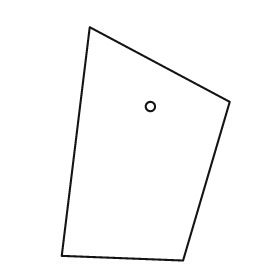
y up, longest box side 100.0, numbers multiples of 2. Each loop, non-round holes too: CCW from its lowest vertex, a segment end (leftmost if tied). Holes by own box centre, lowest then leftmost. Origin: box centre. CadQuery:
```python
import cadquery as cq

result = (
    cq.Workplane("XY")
    .moveTo(16.0, -50.0)
    .lineTo(36.0, 18.0)
    .lineTo(-24.0, 50.0)
    .lineTo(-36.0, -48.0)
    .close()
    .moveTo(2.0, 16.0)
    .circle(2.0)
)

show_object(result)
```